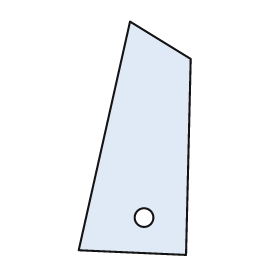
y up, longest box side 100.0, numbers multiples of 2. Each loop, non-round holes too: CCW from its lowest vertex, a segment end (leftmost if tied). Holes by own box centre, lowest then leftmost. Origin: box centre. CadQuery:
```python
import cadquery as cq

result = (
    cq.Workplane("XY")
    .moveTo(22.0, -50.0)
    .lineTo(24.0, 34.0)
    .lineTo(-2.0, 50.0)
    .lineTo(-24.0, -48.0)
    .close()
    .moveTo(4.0, -34.0)
    .circle(4.0)
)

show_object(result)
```